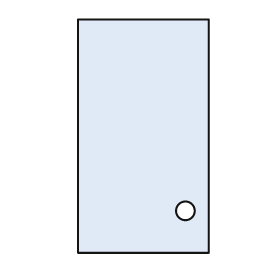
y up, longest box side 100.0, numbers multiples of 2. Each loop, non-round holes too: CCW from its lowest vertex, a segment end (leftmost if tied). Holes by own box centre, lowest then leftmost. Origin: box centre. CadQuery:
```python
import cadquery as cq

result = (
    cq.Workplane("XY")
    .moveTo(-28.0, -50.0)
    .lineTo(28.0, -50.0)
    .lineTo(28.0, 50.0)
    .lineTo(-28.0, 50.0)
    .close()
    .moveTo(18.0, -32.0)
    .circle(4.0)
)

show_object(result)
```